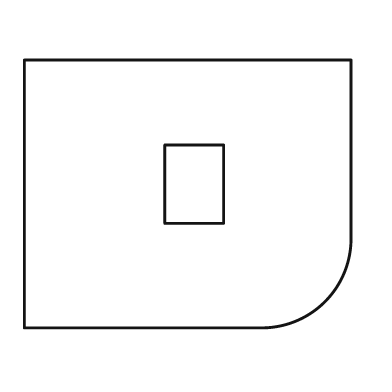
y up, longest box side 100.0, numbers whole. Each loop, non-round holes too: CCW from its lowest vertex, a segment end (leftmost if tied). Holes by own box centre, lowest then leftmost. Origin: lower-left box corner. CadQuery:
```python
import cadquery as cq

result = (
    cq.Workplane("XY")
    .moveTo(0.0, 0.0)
    .lineTo(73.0, 0.0)
    .threePointArc((92.0, 8.0), (100.0, 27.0))
    .lineTo(100.0, 82.0)
    .lineTo(0.0, 82.0)
    .close()
    .moveTo(43.0, 32.0)
    .lineTo(61.0, 32.0)
    .lineTo(61.0, 56.0)
    .lineTo(43.0, 56.0)
    .close()
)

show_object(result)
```